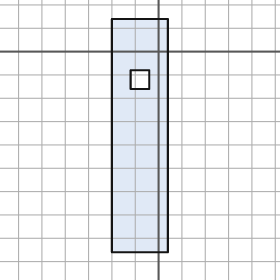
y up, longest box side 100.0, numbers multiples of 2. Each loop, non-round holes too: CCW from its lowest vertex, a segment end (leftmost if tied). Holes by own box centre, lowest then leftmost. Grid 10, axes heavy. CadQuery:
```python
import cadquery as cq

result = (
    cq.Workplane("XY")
    .moveTo(-20.0, -86.0)
    .lineTo(4.0, -86.0)
    .lineTo(4.0, 14.0)
    .lineTo(-20.0, 14.0)
    .close()
    .moveTo(-12.0, -16.0)
    .lineTo(-4.0, -16.0)
    .lineTo(-4.0, -8.0)
    .lineTo(-12.0, -8.0)
    .close()
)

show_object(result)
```